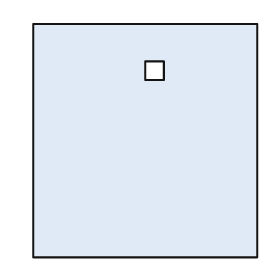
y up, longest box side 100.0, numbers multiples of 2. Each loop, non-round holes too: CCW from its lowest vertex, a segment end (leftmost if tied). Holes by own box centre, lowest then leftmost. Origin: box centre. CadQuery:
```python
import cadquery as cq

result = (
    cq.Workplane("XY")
    .moveTo(-48.0, -50.0)
    .lineTo(48.0, -50.0)
    .lineTo(48.0, 50.0)
    .lineTo(-48.0, 50.0)
    .close()
    .moveTo(0.0, 26.0)
    .lineTo(8.0, 26.0)
    .lineTo(8.0, 34.0)
    .lineTo(0.0, 34.0)
    .close()
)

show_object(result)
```